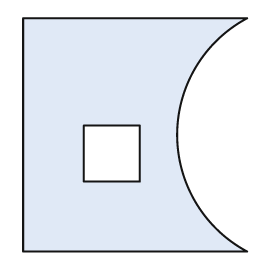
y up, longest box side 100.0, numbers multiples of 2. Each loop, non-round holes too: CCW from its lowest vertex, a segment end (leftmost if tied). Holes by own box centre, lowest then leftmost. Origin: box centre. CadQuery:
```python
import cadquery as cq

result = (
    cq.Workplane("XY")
    .moveTo(-48.0, -50.0)
    .lineTo(48.0, -50.0)
    .threePointArc((18.0, 0.0), (48.0, 50.0))
    .lineTo(-48.0, 50.0)
    .close()
    .moveTo(-22.0, -20.0)
    .lineTo(2.0, -20.0)
    .lineTo(2.0, 4.0)
    .lineTo(-22.0, 4.0)
    .close()
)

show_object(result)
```